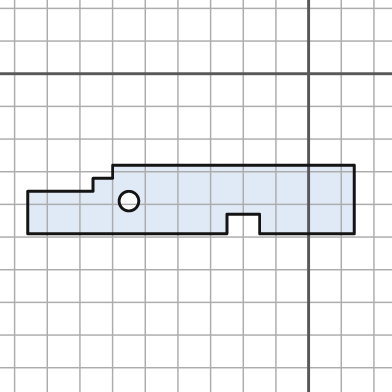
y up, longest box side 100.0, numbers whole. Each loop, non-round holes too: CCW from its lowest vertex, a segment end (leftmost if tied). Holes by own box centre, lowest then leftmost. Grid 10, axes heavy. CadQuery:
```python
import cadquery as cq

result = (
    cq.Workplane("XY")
    .moveTo(-86.0, -49.0)
    .lineTo(-25.0, -49.0)
    .lineTo(-25.0, -43.0)
    .lineTo(-15.0, -43.0)
    .lineTo(-15.0, -49.0)
    .lineTo(14.0, -49.0)
    .lineTo(14.0, -28.0)
    .lineTo(-60.0, -28.0)
    .lineTo(-60.0, -32.0)
    .lineTo(-66.0, -32.0)
    .lineTo(-66.0, -36.0)
    .lineTo(-86.0, -36.0)
    .close()
    .moveTo(-55.0, -39.0)
    .circle(3.0)
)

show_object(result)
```